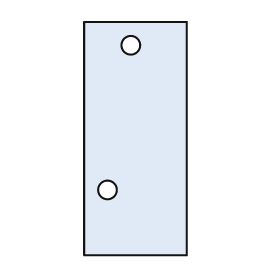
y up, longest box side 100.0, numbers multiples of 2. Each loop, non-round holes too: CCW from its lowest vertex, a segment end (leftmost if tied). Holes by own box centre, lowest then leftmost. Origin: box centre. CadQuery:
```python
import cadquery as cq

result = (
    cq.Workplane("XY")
    .moveTo(-22.0, -50.0)
    .lineTo(22.0, -50.0)
    .lineTo(22.0, 50.0)
    .lineTo(-22.0, 50.0)
    .close()
    .moveTo(-12.0, -22.0)
    .circle(4.0)
    .moveTo(-2.0, 40.0)
    .circle(4.0)
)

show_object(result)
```